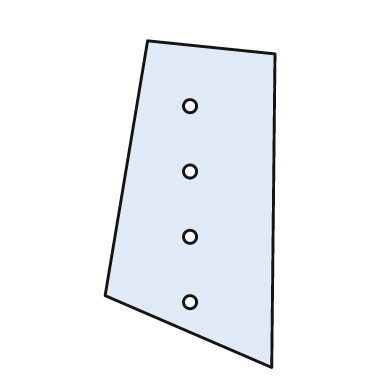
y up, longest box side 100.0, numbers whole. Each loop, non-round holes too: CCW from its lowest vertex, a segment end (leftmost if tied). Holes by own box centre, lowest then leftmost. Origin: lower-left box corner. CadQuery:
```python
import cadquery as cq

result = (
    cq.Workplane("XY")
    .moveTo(51.0, 0.0)
    .lineTo(52.0, 96.0)
    .lineTo(13.0, 100.0)
    .lineTo(0.0, 22.0)
    .close()
    .moveTo(26.0, 20.0)
    .circle(2.0)
    .moveTo(26.0, 40.0)
    .circle(2.0)
    .moveTo(26.0, 60.0)
    .circle(2.0)
    .moveTo(26.0, 80.0)
    .circle(2.0)
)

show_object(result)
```